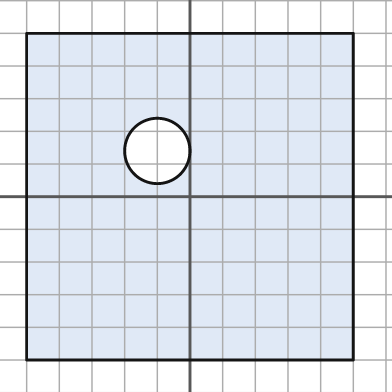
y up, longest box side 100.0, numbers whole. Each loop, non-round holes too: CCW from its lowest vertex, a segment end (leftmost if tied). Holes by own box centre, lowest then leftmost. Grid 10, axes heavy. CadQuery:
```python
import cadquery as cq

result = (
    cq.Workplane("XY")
    .moveTo(-50.0, -50.0)
    .lineTo(50.0, -50.0)
    .lineTo(50.0, 50.0)
    .lineTo(-50.0, 50.0)
    .close()
    .moveTo(-10.0, 14.0)
    .circle(10.0)
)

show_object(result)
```